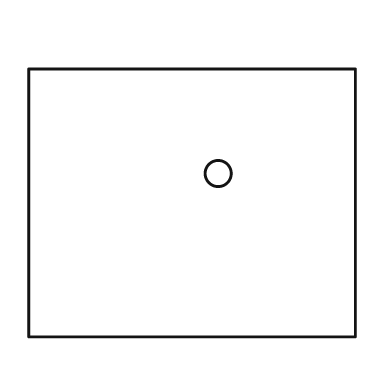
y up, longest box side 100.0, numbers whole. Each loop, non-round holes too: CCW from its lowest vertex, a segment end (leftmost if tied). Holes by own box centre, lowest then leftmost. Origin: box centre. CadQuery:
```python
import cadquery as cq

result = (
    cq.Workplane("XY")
    .moveTo(-50.0, -41.0)
    .lineTo(50.0, -41.0)
    .lineTo(50.0, 41.0)
    .lineTo(-50.0, 41.0)
    .close()
    .moveTo(8.0, 9.0)
    .circle(4.0)
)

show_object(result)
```